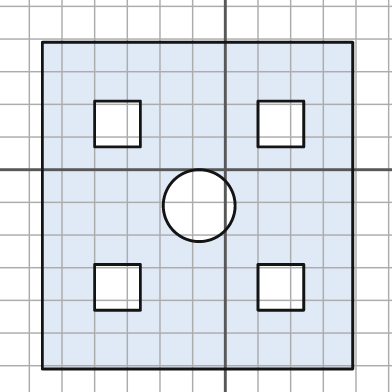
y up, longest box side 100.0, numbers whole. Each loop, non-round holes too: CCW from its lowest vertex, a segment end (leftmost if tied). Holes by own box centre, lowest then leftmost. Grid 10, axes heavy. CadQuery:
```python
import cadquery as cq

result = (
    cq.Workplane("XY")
    .moveTo(-56.0, -61.0)
    .lineTo(39.0, -61.0)
    .lineTo(39.0, 39.0)
    .lineTo(-56.0, 39.0)
    .close()
    .moveTo(-40.0, -43.0)
    .lineTo(-26.0, -43.0)
    .lineTo(-26.0, -29.0)
    .lineTo(-40.0, -29.0)
    .close()
    .moveTo(10.0, -43.0)
    .lineTo(24.0, -43.0)
    .lineTo(24.0, -29.0)
    .lineTo(10.0, -29.0)
    .close()
    .moveTo(-8.0, -11.0)
    .circle(11.0)
    .moveTo(-40.0, 7.0)
    .lineTo(-26.0, 7.0)
    .lineTo(-26.0, 21.0)
    .lineTo(-40.0, 21.0)
    .close()
    .moveTo(10.0, 7.0)
    .lineTo(24.0, 7.0)
    .lineTo(24.0, 21.0)
    .lineTo(10.0, 21.0)
    .close()
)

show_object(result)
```